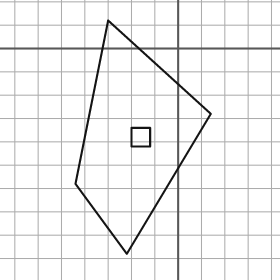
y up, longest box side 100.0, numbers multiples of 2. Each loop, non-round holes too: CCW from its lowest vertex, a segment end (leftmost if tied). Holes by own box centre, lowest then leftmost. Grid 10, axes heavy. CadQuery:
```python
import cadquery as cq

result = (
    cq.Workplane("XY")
    .moveTo(-22.0, -88.0)
    .lineTo(14.0, -28.0)
    .lineTo(-30.0, 12.0)
    .lineTo(-44.0, -58.0)
    .close()
    .moveTo(-20.0, -42.0)
    .lineTo(-12.0, -42.0)
    .lineTo(-12.0, -34.0)
    .lineTo(-20.0, -34.0)
    .close()
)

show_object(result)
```